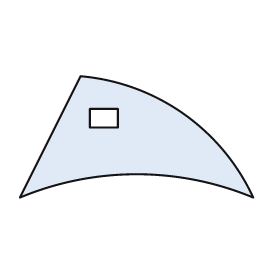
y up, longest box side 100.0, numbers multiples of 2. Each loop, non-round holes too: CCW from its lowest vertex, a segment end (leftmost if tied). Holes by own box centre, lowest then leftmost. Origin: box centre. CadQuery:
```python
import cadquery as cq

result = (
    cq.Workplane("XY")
    .moveTo(-50.0, -26.0)
    .threePointArc((0.0, -16.0), (50.0, -26.0))
    .threePointArc((20.0, 10.0), (-24.0, 26.0))
    .close()
    .moveTo(-20.0, 4.0)
    .lineTo(-8.0, 4.0)
    .lineTo(-8.0, 12.0)
    .lineTo(-20.0, 12.0)
    .close()
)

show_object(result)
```